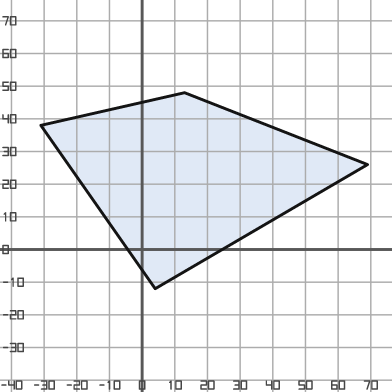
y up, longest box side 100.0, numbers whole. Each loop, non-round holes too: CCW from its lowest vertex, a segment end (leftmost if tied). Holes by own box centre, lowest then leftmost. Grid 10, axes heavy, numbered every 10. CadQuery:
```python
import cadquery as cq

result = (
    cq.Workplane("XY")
    .moveTo(4.0, -12.0)
    .lineTo(69.0, 26.0)
    .lineTo(13.0, 48.0)
    .lineTo(-31.0, 38.0)
    .close()
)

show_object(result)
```